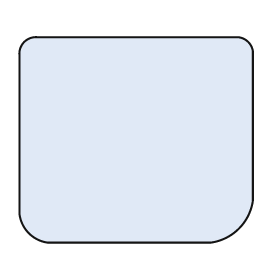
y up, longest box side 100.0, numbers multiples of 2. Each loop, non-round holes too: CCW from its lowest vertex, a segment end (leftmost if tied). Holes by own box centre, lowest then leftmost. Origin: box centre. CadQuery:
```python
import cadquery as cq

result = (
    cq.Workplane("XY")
    .moveTo(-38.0, -44.0)
    .lineTo(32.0, -44.0)
    .threePointArc((44.0, -38.0), (50.0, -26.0))
    .lineTo(50.0, 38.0)
    .threePointArc((48.0, 42.0), (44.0, 44.0))
    .lineTo(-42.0, 44.0)
    .threePointArc((-48.0, 42.0), (-50.0, 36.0))
    .lineTo(-50.0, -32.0)
    .threePointArc((-46.0, -40.0), (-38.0, -44.0))
    .close()
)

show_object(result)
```